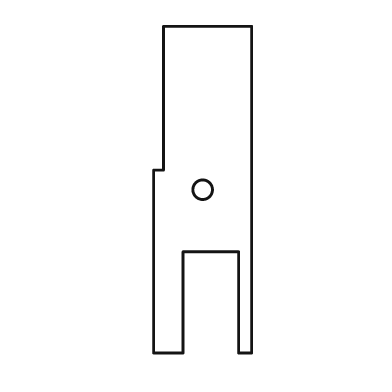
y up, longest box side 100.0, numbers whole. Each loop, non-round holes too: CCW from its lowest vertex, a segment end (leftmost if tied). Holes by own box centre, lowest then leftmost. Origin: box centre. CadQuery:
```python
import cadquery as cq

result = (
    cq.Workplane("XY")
    .moveTo(-15.0, -50.0)
    .lineTo(-6.0, -50.0)
    .lineTo(-6.0, -19.0)
    .lineTo(11.0, -19.0)
    .lineTo(11.0, -50.0)
    .lineTo(15.0, -50.0)
    .lineTo(15.0, 50.0)
    .lineTo(-12.0, 50.0)
    .lineTo(-12.0, 6.0)
    .lineTo(-15.0, 6.0)
    .close()
    .moveTo(0.0, 0.0)
    .circle(3.0)
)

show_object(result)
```